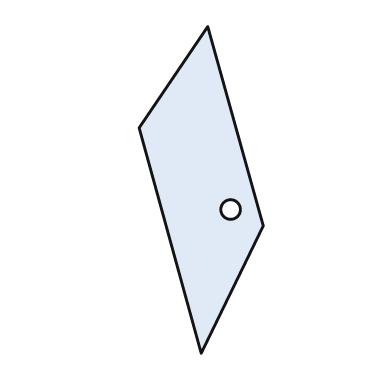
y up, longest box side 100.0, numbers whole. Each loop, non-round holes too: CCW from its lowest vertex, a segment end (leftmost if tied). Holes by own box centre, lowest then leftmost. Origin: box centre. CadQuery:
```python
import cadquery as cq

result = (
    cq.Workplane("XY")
    .moveTo(0.0, -50.0)
    .lineTo(19.0, -11.0)
    .lineTo(2.0, 50.0)
    .lineTo(-19.0, 19.0)
    .close()
    .moveTo(9.0, -6.0)
    .circle(3.0)
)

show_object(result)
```